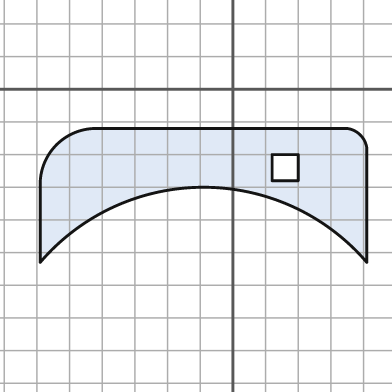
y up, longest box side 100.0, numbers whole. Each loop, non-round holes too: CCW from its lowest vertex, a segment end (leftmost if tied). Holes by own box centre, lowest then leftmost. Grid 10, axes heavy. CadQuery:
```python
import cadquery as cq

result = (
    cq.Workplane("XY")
    .moveTo(-59.0, -53.0)
    .threePointArc((-9.0, -30.0), (41.0, -53.0))
    .lineTo(41.0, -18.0)
    .threePointArc((39.0, -14.0), (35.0, -12.0))
    .lineTo(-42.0, -12.0)
    .threePointArc((-54.0, -17.0), (-59.0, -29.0))
    .close()
    .moveTo(12.0, -28.0)
    .lineTo(20.0, -28.0)
    .lineTo(20.0, -20.0)
    .lineTo(12.0, -20.0)
    .close()
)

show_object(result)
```